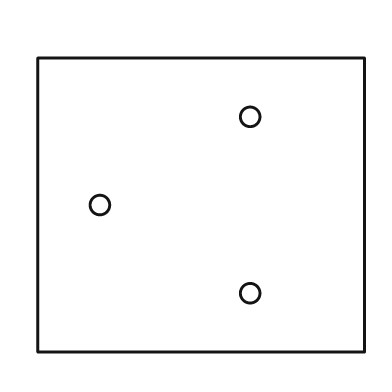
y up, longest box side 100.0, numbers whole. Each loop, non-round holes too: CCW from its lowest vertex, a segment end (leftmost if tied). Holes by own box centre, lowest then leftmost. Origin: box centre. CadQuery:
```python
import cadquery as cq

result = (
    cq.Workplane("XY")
    .moveTo(-50.0, -45.0)
    .lineTo(50.0, -45.0)
    .lineTo(50.0, 45.0)
    .lineTo(-50.0, 45.0)
    .close()
    .moveTo(15.0, -27.0)
    .circle(3.0)
    .moveTo(-31.0, 0.0)
    .circle(3.0)
    .moveTo(15.0, 27.0)
    .circle(3.0)
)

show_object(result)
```